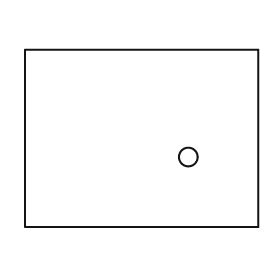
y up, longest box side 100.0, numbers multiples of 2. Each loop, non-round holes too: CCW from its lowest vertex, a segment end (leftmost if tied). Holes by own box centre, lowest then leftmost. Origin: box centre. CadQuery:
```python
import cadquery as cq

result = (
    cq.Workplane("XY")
    .moveTo(-50.0, -38.0)
    .lineTo(50.0, -38.0)
    .lineTo(50.0, 38.0)
    .lineTo(-50.0, 38.0)
    .close()
    .moveTo(20.0, -8.0)
    .circle(4.0)
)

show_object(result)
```